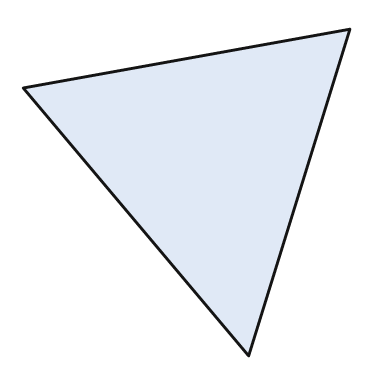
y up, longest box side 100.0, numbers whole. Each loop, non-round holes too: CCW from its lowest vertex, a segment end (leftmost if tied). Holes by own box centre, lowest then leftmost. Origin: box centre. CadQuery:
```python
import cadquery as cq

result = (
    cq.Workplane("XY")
    .moveTo(19.0, -50.0)
    .lineTo(50.0, 50.0)
    .lineTo(-50.0, 32.0)
    .close()
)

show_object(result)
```